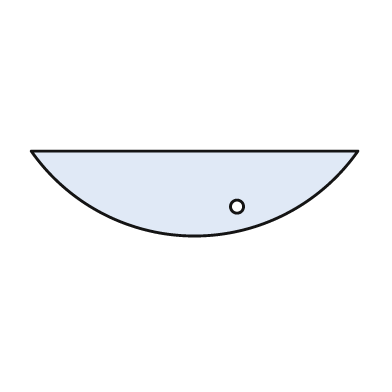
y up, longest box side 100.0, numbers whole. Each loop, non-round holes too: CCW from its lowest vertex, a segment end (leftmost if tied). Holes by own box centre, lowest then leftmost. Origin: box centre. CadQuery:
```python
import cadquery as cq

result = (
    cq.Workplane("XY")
    .moveTo(-50.0, 13.0)
    .threePointArc((0.0, -13.0), (50.0, 13.0))
    .close()
    .moveTo(13.0, -4.0)
    .circle(2.0)
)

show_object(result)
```